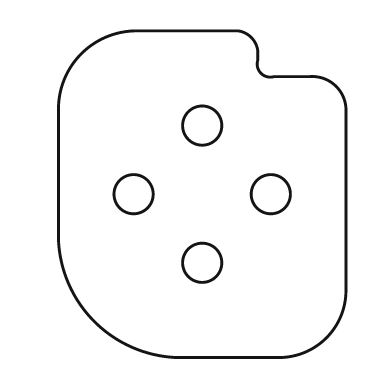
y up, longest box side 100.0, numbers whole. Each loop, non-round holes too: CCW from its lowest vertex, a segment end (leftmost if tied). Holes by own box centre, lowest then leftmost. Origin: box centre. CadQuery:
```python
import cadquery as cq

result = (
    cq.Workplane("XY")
    .moveTo(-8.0, -50.0)
    .lineTo(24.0, -50.0)
    .threePointArc((38.0, -44.0), (44.0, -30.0))
    .lineTo(44.0, 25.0)
    .threePointArc((41.0, 33.0), (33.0, 36.0))
    .lineTo(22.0, 36.0)
    .threePointArc((18.0, 37.0), (17.0, 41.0))
    .lineTo(17.0, 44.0)
    .threePointArc((15.0, 48.0), (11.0, 50.0))
    .lineTo(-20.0, 50.0)
    .threePointArc((-37.0, 43.0), (-44.0, 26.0))
    .lineTo(-44.0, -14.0)
    .threePointArc((-33.0, -39.0), (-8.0, -50.0))
    .close()
    .moveTo(0.0, -21.0)
    .circle(6.0)
    .moveTo(-21.0, 0.0)
    .circle(6.0)
    .moveTo(21.0, 0.0)
    .circle(6.0)
    .moveTo(0.0, 21.0)
    .circle(6.0)
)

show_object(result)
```